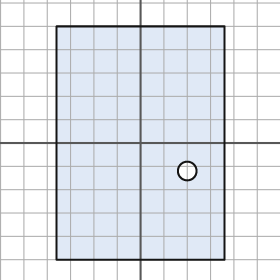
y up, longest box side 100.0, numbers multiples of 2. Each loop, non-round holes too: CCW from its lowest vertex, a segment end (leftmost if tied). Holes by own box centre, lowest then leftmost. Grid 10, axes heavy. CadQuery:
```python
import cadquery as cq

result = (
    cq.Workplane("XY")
    .moveTo(-36.0, -50.0)
    .lineTo(36.0, -50.0)
    .lineTo(36.0, 50.0)
    .lineTo(-36.0, 50.0)
    .close()
    .moveTo(20.0, -12.0)
    .circle(4.0)
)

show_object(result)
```